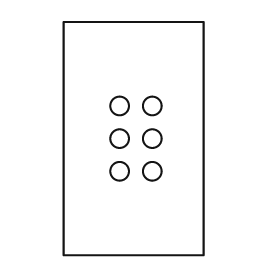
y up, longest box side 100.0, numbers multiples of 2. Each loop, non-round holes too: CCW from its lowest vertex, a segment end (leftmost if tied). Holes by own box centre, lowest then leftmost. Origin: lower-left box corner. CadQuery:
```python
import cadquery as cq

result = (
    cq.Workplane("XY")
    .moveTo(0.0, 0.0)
    .lineTo(60.0, 0.0)
    .lineTo(60.0, 100.0)
    .lineTo(0.0, 100.0)
    .close()
    .moveTo(24.0, 36.0)
    .circle(4.0)
    .moveTo(38.0, 36.0)
    .circle(4.0)
    .moveTo(24.0, 50.0)
    .circle(4.0)
    .moveTo(38.0, 50.0)
    .circle(4.0)
    .moveTo(24.0, 64.0)
    .circle(4.0)
    .moveTo(38.0, 64.0)
    .circle(4.0)
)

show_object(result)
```